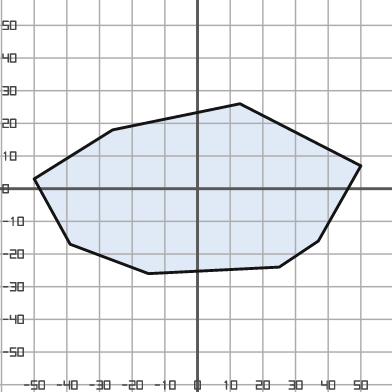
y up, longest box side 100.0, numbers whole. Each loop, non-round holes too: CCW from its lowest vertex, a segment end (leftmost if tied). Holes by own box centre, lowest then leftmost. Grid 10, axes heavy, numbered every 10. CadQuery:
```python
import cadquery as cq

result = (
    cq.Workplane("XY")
    .moveTo(-15.0, -26.0)
    .lineTo(25.0, -24.0)
    .lineTo(37.0, -16.0)
    .lineTo(50.0, 7.0)
    .lineTo(13.0, 26.0)
    .lineTo(-26.0, 18.0)
    .lineTo(-50.0, 3.0)
    .lineTo(-39.0, -17.0)
    .close()
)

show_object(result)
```